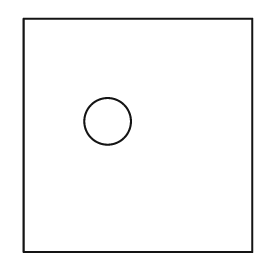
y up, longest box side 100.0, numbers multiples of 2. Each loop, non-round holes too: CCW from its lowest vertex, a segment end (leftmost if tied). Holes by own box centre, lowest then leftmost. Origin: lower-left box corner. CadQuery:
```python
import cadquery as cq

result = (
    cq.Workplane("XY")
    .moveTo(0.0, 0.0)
    .lineTo(98.0, 0.0)
    .lineTo(98.0, 100.0)
    .lineTo(0.0, 100.0)
    .close()
    .moveTo(36.0, 56.0)
    .circle(10.0)
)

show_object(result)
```